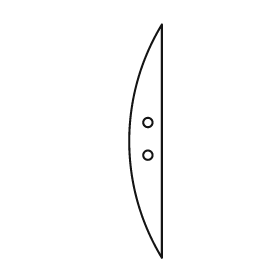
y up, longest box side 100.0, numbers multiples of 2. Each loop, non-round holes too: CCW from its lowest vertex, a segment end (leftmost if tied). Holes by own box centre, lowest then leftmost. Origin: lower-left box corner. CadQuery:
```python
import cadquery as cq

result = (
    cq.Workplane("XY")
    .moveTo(14.0, 0.0)
    .lineTo(14.0, 100.0)
    .threePointArc((0.0, 50.0), (14.0, 0.0))
    .close()
    .moveTo(8.0, 44.0)
    .circle(2.0)
    .moveTo(8.0, 58.0)
    .circle(2.0)
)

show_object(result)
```